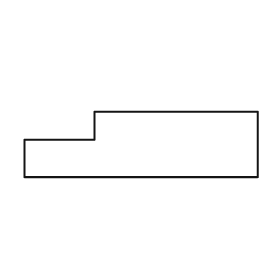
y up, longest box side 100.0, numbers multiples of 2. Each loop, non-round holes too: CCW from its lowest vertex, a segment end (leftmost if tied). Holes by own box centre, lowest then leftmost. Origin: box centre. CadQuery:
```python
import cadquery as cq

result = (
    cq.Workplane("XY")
    .moveTo(-50.0, -14.0)
    .lineTo(50.0, -14.0)
    .lineTo(50.0, 14.0)
    .lineTo(-20.0, 14.0)
    .lineTo(-20.0, 2.0)
    .lineTo(-50.0, 2.0)
    .close()
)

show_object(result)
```